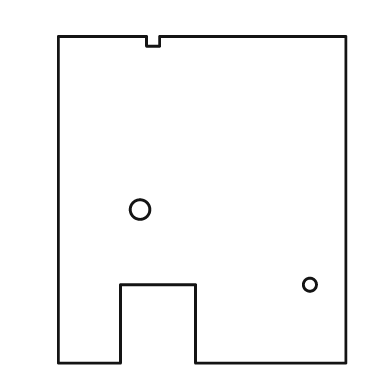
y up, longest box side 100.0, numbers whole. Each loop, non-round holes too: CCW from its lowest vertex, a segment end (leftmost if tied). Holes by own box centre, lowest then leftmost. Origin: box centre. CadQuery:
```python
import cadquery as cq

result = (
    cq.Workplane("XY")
    .moveTo(-44.0, -50.0)
    .lineTo(-25.0, -50.0)
    .lineTo(-25.0, -26.0)
    .lineTo(-2.0, -26.0)
    .lineTo(-2.0, -50.0)
    .lineTo(44.0, -50.0)
    .lineTo(44.0, 50.0)
    .lineTo(-13.0, 50.0)
    .lineTo(-13.0, 47.0)
    .lineTo(-17.0, 47.0)
    .lineTo(-17.0, 50.0)
    .lineTo(-44.0, 50.0)
    .close()
    .moveTo(33.0, -26.0)
    .circle(2.0)
    .moveTo(-19.0, -3.0)
    .circle(3.0)
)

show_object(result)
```